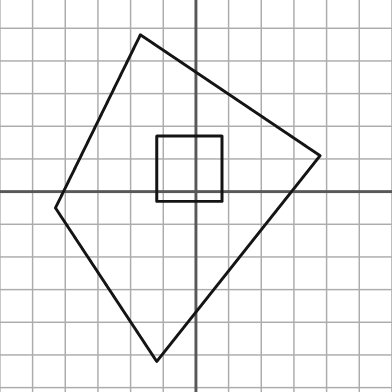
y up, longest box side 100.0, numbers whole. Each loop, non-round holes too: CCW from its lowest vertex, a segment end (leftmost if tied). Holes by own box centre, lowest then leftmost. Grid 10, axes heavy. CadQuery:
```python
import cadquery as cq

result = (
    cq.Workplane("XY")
    .moveTo(-12.0, -52.0)
    .lineTo(38.0, 11.0)
    .lineTo(-17.0, 48.0)
    .lineTo(-43.0, -5.0)
    .close()
    .moveTo(-12.0, -3.0)
    .lineTo(8.0, -3.0)
    .lineTo(8.0, 17.0)
    .lineTo(-12.0, 17.0)
    .close()
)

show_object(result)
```